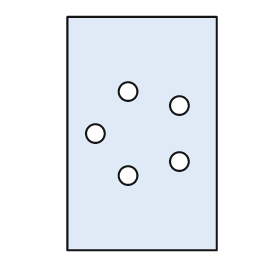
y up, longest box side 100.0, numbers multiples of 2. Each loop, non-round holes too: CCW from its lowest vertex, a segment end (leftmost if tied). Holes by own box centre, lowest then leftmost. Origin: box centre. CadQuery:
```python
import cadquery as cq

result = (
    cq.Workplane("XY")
    .moveTo(-32.0, -50.0)
    .lineTo(32.0, -50.0)
    .lineTo(32.0, 50.0)
    .lineTo(-32.0, 50.0)
    .close()
    .moveTo(-6.0, -18.0)
    .circle(4.0)
    .moveTo(16.0, -12.0)
    .circle(4.0)
    .moveTo(-20.0, 0.0)
    .circle(4.0)
    .moveTo(16.0, 12.0)
    .circle(4.0)
    .moveTo(-6.0, 18.0)
    .circle(4.0)
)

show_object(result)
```